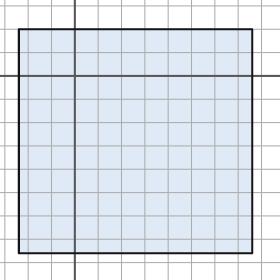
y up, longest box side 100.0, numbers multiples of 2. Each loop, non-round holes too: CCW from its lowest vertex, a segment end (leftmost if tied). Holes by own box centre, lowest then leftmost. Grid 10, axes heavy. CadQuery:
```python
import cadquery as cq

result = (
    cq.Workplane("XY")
    .moveTo(-24.0, -76.0)
    .lineTo(76.0, -76.0)
    .lineTo(76.0, 20.0)
    .lineTo(-24.0, 20.0)
    .close()
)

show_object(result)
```